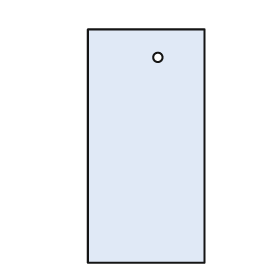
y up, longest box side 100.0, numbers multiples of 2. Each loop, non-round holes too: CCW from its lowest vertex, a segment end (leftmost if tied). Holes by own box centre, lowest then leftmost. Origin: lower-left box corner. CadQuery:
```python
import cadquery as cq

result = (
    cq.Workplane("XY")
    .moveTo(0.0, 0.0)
    .lineTo(50.0, 0.0)
    .lineTo(50.0, 100.0)
    .lineTo(0.0, 100.0)
    .close()
    .moveTo(30.0, 88.0)
    .circle(2.0)
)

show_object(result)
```